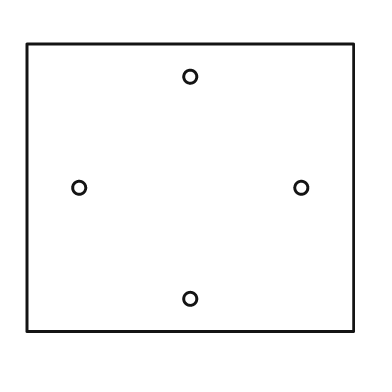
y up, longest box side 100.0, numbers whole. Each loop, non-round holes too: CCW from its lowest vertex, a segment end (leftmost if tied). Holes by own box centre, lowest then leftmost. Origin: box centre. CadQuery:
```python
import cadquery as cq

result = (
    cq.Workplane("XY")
    .moveTo(-50.0, -44.0)
    .lineTo(50.0, -44.0)
    .lineTo(50.0, 44.0)
    .lineTo(-50.0, 44.0)
    .close()
    .moveTo(0.0, -34.0)
    .circle(2.0)
    .moveTo(-34.0, 0.0)
    .circle(2.0)
    .moveTo(34.0, 0.0)
    .circle(2.0)
    .moveTo(0.0, 34.0)
    .circle(2.0)
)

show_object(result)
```